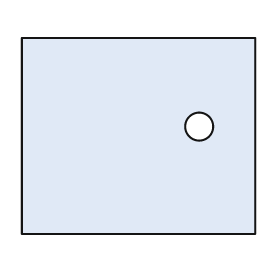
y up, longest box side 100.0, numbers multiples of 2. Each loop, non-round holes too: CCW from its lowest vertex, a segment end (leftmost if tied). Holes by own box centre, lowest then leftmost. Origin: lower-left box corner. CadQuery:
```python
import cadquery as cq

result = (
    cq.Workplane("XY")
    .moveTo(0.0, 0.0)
    .lineTo(100.0, 0.0)
    .lineTo(100.0, 84.0)
    .lineTo(0.0, 84.0)
    .close()
    .moveTo(76.0, 46.0)
    .circle(6.0)
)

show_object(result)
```